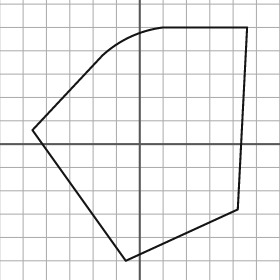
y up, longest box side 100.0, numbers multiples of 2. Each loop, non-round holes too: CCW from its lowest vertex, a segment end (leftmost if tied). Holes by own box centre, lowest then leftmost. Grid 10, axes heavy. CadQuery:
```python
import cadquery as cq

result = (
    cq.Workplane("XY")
    .moveTo(-6.0, -50.0)
    .lineTo(42.0, -28.0)
    .lineTo(46.0, 50.0)
    .lineTo(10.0, 50.0)
    .threePointArc((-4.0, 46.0), (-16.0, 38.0))
    .lineTo(-46.0, 6.0)
    .close()
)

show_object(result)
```